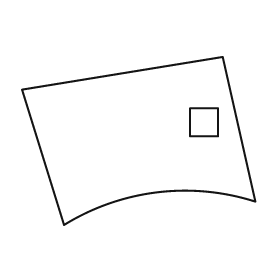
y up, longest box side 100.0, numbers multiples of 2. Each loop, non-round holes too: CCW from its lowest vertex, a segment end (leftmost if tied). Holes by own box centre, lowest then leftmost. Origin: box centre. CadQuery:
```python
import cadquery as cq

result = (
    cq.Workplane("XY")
    .moveTo(-32.0, -36.0)
    .threePointArc((8.0, -22.0), (50.0, -26.0))
    .lineTo(36.0, 36.0)
    .lineTo(-50.0, 22.0)
    .close()
    .moveTo(22.0, 2.0)
    .lineTo(34.0, 2.0)
    .lineTo(34.0, 14.0)
    .lineTo(22.0, 14.0)
    .close()
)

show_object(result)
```